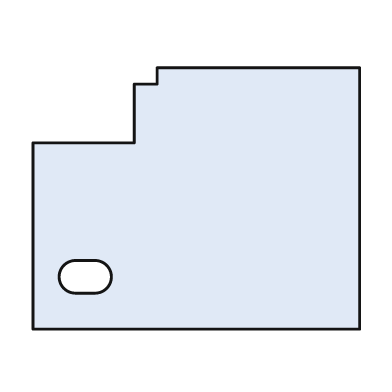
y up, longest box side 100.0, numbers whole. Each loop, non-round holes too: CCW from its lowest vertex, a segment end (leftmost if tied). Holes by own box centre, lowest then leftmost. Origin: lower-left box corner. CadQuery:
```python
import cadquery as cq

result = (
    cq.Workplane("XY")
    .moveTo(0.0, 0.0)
    .lineTo(100.0, 0.0)
    .lineTo(100.0, 80.0)
    .lineTo(38.0, 80.0)
    .lineTo(38.0, 75.0)
    .lineTo(31.0, 75.0)
    .lineTo(31.0, 57.0)
    .lineTo(0.0, 57.0)
    .close()
    .moveTo(13.0, 11.0)
    .lineTo(19.0, 11.0)
    .threePointArc((24.0, 16.0), (19.0, 21.0))
    .lineTo(13.0, 21.0)
    .threePointArc((8.0, 16.0), (13.0, 11.0))
    .close()
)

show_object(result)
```